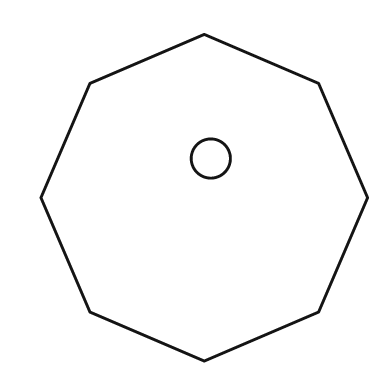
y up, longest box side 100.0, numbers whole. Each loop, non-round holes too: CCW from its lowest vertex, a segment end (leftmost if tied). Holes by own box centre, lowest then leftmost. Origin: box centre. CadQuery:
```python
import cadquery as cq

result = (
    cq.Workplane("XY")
    .moveTo(0.0, -50.0)
    .lineTo(35.0, -35.0)
    .lineTo(50.0, 0.0)
    .lineTo(35.0, 35.0)
    .lineTo(0.0, 50.0)
    .lineTo(-35.0, 35.0)
    .lineTo(-50.0, 0.0)
    .lineTo(-35.0, -35.0)
    .close()
    .moveTo(2.0, 12.0)
    .circle(6.0)
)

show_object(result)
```